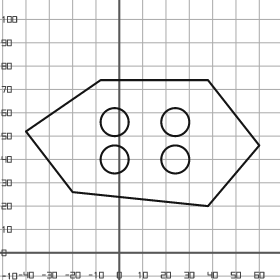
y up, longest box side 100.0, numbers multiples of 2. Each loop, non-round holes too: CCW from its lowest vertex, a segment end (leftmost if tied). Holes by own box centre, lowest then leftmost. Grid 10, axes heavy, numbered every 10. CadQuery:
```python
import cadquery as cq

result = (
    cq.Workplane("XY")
    .moveTo(38.0, 20.0)
    .lineTo(60.0, 46.0)
    .lineTo(38.0, 74.0)
    .lineTo(-8.0, 74.0)
    .lineTo(-40.0, 52.0)
    .lineTo(-20.0, 26.0)
    .close()
    .moveTo(-2.0, 40.0)
    .circle(6.0)
    .moveTo(24.0, 40.0)
    .circle(6.0)
    .moveTo(-2.0, 56.0)
    .circle(6.0)
    .moveTo(24.0, 56.0)
    .circle(6.0)
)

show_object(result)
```